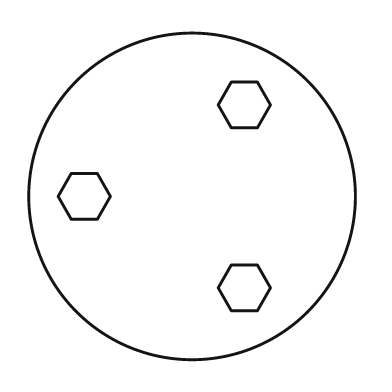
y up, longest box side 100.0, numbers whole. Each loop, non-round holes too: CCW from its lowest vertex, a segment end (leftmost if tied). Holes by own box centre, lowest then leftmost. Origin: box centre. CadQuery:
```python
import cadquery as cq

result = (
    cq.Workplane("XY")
    .moveTo(0.0, 0.0)
    .circle(50.0)
    .moveTo(12.0, -35.0)
    .lineTo(20.0, -35.0)
    .lineTo(24.0, -28.0)
    .lineTo(20.0, -21.0)
    .lineTo(12.0, -21.0)
    .lineTo(8.0, -28.0)
    .close()
    .moveTo(-37.0, -7.0)
    .lineTo(-29.0, -7.0)
    .lineTo(-25.0, 0.0)
    .lineTo(-29.0, 7.0)
    .lineTo(-37.0, 7.0)
    .lineTo(-41.0, 0.0)
    .close()
    .moveTo(12.0, 21.0)
    .lineTo(20.0, 21.0)
    .lineTo(24.0, 28.0)
    .lineTo(20.0, 35.0)
    .lineTo(12.0, 35.0)
    .lineTo(8.0, 28.0)
    .close()
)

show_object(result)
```